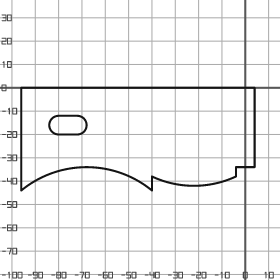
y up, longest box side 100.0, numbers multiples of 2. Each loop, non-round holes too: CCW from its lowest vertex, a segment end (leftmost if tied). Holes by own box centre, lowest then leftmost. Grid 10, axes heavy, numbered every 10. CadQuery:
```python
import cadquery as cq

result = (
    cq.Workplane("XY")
    .moveTo(-96.0, -44.0)
    .threePointArc((-68.0, -34.0), (-40.0, -44.0))
    .lineTo(-40.0, -38.0)
    .threePointArc((-22.0, -42.0), (-4.0, -38.0))
    .lineTo(-4.0, -34.0)
    .lineTo(4.0, -34.0)
    .lineTo(4.0, 0.0)
    .lineTo(-96.0, 0.0)
    .close()
    .moveTo(-80.0, -20.0)
    .lineTo(-72.0, -20.0)
    .threePointArc((-68.0, -16.0), (-72.0, -12.0))
    .lineTo(-80.0, -12.0)
    .threePointArc((-84.0, -16.0), (-80.0, -20.0))
    .close()
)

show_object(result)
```